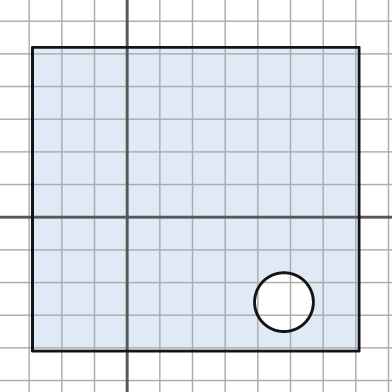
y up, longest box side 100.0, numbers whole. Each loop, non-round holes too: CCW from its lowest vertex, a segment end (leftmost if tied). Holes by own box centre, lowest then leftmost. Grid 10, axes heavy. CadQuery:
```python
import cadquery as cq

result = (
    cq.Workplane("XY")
    .moveTo(-29.0, -41.0)
    .lineTo(71.0, -41.0)
    .lineTo(71.0, 52.0)
    .lineTo(-29.0, 52.0)
    .close()
    .moveTo(48.0, -26.0)
    .circle(9.0)
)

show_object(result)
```